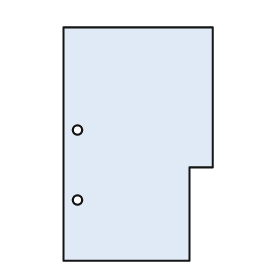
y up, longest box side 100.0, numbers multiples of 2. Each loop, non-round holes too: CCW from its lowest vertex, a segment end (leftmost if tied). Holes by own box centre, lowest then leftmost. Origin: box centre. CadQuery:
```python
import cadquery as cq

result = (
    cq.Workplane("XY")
    .moveTo(-32.0, -50.0)
    .lineTo(22.0, -50.0)
    .lineTo(22.0, -10.0)
    .lineTo(32.0, -10.0)
    .lineTo(32.0, 50.0)
    .lineTo(-32.0, 50.0)
    .close()
    .moveTo(-26.0, -24.0)
    .circle(2.0)
    .moveTo(-26.0, 6.0)
    .circle(2.0)
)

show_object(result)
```